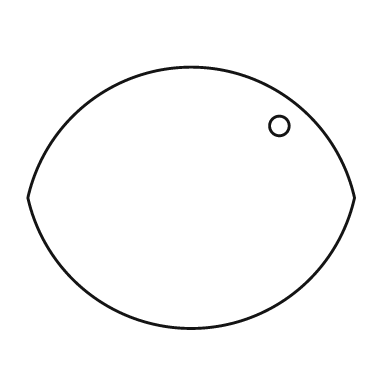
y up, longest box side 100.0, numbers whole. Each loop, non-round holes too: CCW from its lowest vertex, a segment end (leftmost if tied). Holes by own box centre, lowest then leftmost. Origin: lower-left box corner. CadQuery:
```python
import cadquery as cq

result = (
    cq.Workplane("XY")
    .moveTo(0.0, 40.0)
    .threePointArc((50.0, 0.0), (100.0, 40.0))
    .threePointArc((50.0, 80.0), (0.0, 40.0))
    .close()
    .moveTo(77.0, 62.0)
    .circle(3.0)
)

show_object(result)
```